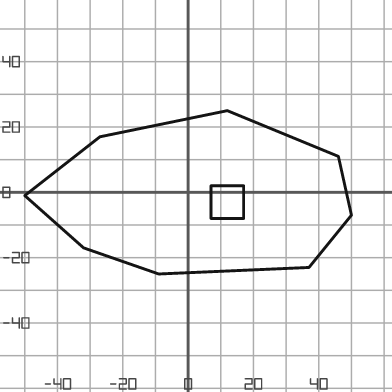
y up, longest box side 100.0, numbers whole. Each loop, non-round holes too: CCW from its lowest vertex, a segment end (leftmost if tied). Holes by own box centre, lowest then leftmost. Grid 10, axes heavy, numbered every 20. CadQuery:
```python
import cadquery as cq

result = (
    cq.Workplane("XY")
    .moveTo(-9.0, -25.0)
    .lineTo(37.0, -23.0)
    .lineTo(50.0, -7.0)
    .lineTo(46.0, 11.0)
    .lineTo(12.0, 25.0)
    .lineTo(-27.0, 17.0)
    .lineTo(-50.0, -1.0)
    .lineTo(-32.0, -17.0)
    .close()
    .moveTo(7.0, -8.0)
    .lineTo(17.0, -8.0)
    .lineTo(17.0, 2.0)
    .lineTo(7.0, 2.0)
    .close()
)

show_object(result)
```